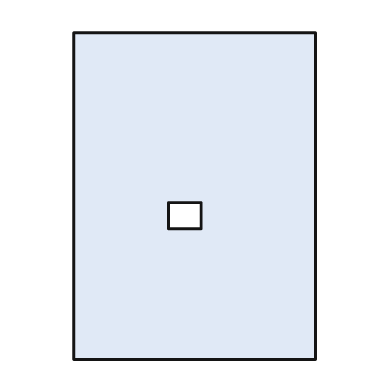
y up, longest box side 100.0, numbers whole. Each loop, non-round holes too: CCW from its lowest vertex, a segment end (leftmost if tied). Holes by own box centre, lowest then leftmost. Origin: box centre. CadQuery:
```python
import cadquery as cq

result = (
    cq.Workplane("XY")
    .moveTo(-37.0, -50.0)
    .lineTo(37.0, -50.0)
    .lineTo(37.0, 50.0)
    .lineTo(-37.0, 50.0)
    .close()
    .moveTo(-8.0, -10.0)
    .lineTo(2.0, -10.0)
    .lineTo(2.0, -2.0)
    .lineTo(-8.0, -2.0)
    .close()
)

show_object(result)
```